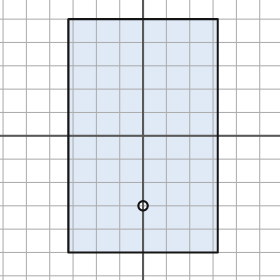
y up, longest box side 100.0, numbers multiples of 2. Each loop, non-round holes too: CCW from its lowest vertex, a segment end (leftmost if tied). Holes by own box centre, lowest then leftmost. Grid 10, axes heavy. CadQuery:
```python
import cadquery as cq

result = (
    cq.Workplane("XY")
    .moveTo(-32.0, -50.0)
    .lineTo(32.0, -50.0)
    .lineTo(32.0, 50.0)
    .lineTo(-32.0, 50.0)
    .close()
    .moveTo(0.0, -30.0)
    .circle(2.0)
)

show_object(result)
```